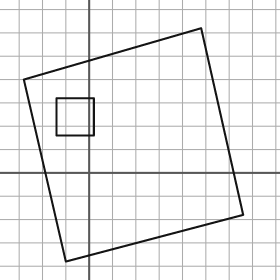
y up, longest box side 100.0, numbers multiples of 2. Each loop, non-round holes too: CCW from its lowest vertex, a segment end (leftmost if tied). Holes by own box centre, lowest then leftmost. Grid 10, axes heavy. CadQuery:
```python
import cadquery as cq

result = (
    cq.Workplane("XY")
    .moveTo(-10.0, -38.0)
    .lineTo(66.0, -18.0)
    .lineTo(48.0, 62.0)
    .lineTo(-28.0, 40.0)
    .close()
    .moveTo(-14.0, 16.0)
    .lineTo(2.0, 16.0)
    .lineTo(2.0, 32.0)
    .lineTo(-14.0, 32.0)
    .close()
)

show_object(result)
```